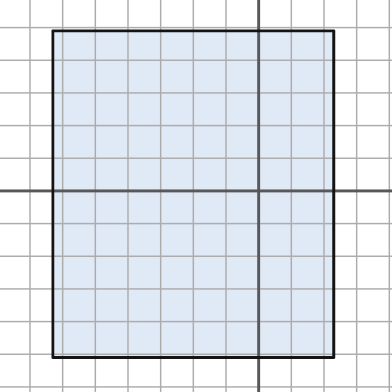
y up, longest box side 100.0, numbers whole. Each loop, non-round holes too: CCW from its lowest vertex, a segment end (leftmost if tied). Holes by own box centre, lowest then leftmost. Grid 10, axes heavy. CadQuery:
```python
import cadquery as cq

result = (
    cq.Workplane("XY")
    .moveTo(-63.0, -51.0)
    .lineTo(23.0, -51.0)
    .lineTo(23.0, 49.0)
    .lineTo(-63.0, 49.0)
    .close()
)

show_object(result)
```